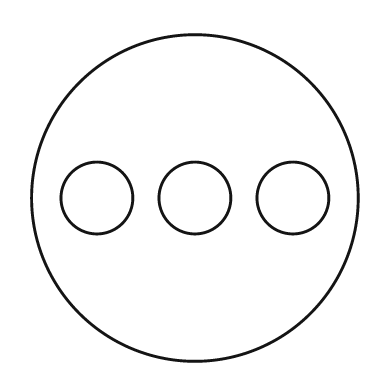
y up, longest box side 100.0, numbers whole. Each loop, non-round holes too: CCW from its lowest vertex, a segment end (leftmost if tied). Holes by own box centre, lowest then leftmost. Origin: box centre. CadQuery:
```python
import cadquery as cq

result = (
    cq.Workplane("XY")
    .moveTo(0.0, 0.0)
    .circle(50.0)
    .moveTo(-30.0, 0.0)
    .circle(11.0)
    .moveTo(0.0, 0.0)
    .circle(11.0)
    .moveTo(30.0, 0.0)
    .circle(11.0)
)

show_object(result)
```